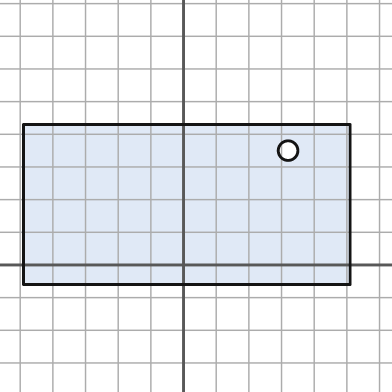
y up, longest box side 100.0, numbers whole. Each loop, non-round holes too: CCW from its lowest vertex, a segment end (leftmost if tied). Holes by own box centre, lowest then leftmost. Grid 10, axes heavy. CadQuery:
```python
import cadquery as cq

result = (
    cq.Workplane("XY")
    .moveTo(-49.0, -6.0)
    .lineTo(51.0, -6.0)
    .lineTo(51.0, 43.0)
    .lineTo(-49.0, 43.0)
    .close()
    .moveTo(32.0, 35.0)
    .circle(3.0)
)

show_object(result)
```